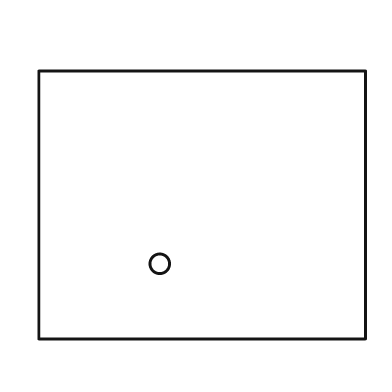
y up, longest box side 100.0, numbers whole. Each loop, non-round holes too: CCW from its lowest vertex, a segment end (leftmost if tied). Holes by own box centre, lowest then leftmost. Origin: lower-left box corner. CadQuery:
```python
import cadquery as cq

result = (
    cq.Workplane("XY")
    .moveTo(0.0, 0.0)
    .lineTo(100.0, 0.0)
    .lineTo(100.0, 82.0)
    .lineTo(0.0, 82.0)
    .close()
    .moveTo(37.0, 23.0)
    .circle(3.0)
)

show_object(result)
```